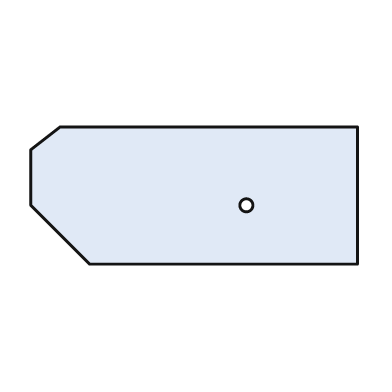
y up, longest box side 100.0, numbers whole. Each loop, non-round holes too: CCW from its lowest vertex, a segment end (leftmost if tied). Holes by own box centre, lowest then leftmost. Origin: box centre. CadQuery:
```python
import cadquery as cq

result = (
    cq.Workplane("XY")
    .moveTo(-32.0, -21.0)
    .lineTo(50.0, -21.0)
    .lineTo(50.0, 21.0)
    .lineTo(-41.0, 21.0)
    .lineTo(-50.0, 14.0)
    .lineTo(-50.0, -3.0)
    .close()
    .moveTo(16.0, -3.0)
    .circle(2.0)
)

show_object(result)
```